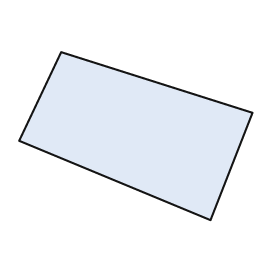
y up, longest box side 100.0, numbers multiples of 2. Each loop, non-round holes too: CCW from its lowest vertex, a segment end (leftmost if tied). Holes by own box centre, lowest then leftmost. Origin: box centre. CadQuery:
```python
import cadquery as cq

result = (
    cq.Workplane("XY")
    .moveTo(32.0, -36.0)
    .lineTo(50.0, 10.0)
    .lineTo(-32.0, 36.0)
    .lineTo(-50.0, -2.0)
    .close()
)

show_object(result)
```